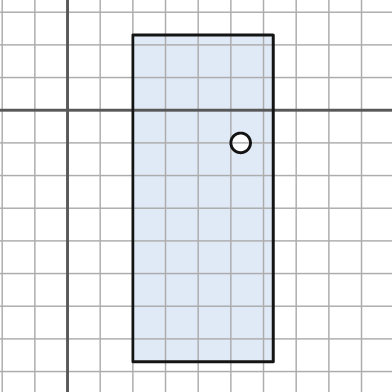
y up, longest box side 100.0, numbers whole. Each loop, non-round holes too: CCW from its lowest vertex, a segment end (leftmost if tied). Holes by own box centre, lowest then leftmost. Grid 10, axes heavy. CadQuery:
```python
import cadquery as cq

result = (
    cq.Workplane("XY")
    .moveTo(20.0, -77.0)
    .lineTo(63.0, -77.0)
    .lineTo(63.0, 23.0)
    .lineTo(20.0, 23.0)
    .close()
    .moveTo(53.0, -10.0)
    .circle(3.0)
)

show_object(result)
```